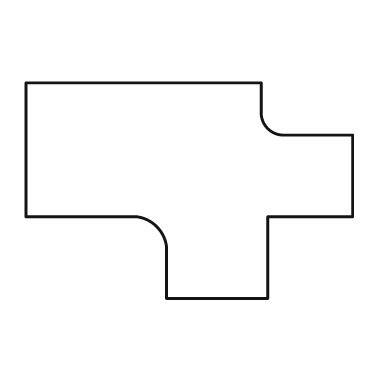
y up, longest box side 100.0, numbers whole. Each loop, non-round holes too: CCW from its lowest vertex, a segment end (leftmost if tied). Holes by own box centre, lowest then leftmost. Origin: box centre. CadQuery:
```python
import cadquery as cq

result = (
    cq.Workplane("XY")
    .moveTo(-7.0, -33.0)
    .lineTo(24.0, -33.0)
    .lineTo(24.0, -8.0)
    .lineTo(50.0, -8.0)
    .lineTo(50.0, 17.0)
    .lineTo(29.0, 17.0)
    .threePointArc((24.0, 19.0), (22.0, 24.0))
    .lineTo(22.0, 33.0)
    .lineTo(-50.0, 33.0)
    .lineTo(-50.0, -8.0)
    .lineTo(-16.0, -8.0)
    .threePointArc((-10.0, -11.0), (-7.0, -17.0))
    .close()
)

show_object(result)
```